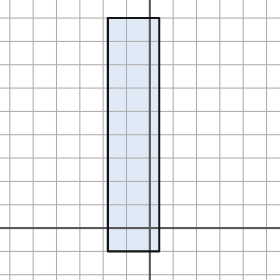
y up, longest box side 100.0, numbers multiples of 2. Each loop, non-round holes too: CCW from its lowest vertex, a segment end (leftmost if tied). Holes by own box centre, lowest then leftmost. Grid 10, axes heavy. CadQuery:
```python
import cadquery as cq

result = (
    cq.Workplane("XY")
    .moveTo(-18.0, -10.0)
    .lineTo(4.0, -10.0)
    .lineTo(4.0, 90.0)
    .lineTo(-18.0, 90.0)
    .close()
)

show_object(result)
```